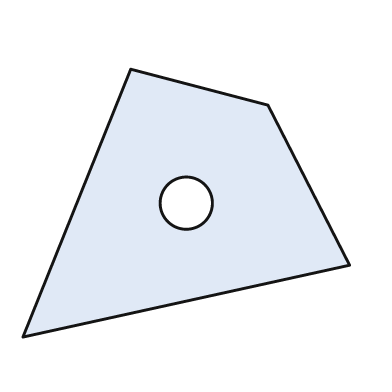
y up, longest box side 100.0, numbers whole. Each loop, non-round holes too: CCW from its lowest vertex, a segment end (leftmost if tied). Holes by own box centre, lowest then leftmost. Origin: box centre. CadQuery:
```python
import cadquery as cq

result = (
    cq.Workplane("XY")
    .moveTo(-50.0, -41.0)
    .lineTo(50.0, -19.0)
    .lineTo(25.0, 30.0)
    .lineTo(-17.0, 41.0)
    .close()
    .moveTo(0.0, 0.0)
    .circle(8.0)
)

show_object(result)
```